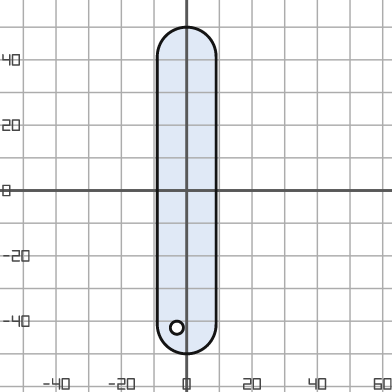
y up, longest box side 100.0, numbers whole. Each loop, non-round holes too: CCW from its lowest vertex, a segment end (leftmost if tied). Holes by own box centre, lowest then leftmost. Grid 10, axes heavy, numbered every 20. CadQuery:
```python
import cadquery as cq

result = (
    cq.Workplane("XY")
    .moveTo(-9.0, -41.0)
    .threePointArc((0.0, -50.0), (9.0, -41.0))
    .lineTo(9.0, 41.0)
    .threePointArc((0.0, 50.0), (-9.0, 41.0))
    .close()
    .moveTo(-3.0, -42.0)
    .circle(2.0)
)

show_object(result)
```